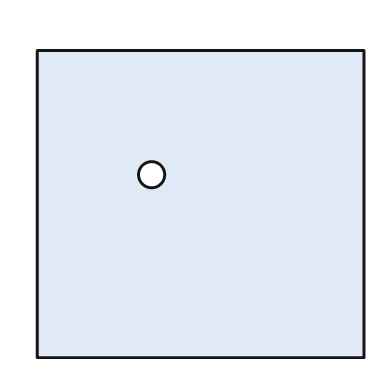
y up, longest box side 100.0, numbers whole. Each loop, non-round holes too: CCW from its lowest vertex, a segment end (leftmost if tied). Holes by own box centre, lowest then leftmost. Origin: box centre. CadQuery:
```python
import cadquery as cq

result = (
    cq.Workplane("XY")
    .moveTo(-50.0, -47.0)
    .lineTo(50.0, -47.0)
    .lineTo(50.0, 47.0)
    .lineTo(-50.0, 47.0)
    .close()
    .moveTo(-15.0, 9.0)
    .circle(4.0)
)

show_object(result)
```